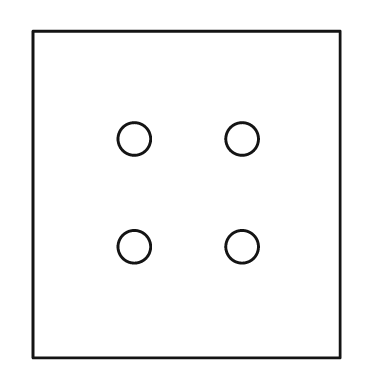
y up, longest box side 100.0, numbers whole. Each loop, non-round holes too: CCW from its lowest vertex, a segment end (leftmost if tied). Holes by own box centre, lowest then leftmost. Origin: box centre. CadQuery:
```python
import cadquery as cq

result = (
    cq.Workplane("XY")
    .moveTo(-47.0, -50.0)
    .lineTo(47.0, -50.0)
    .lineTo(47.0, 50.0)
    .lineTo(-47.0, 50.0)
    .close()
    .moveTo(-16.0, -16.0)
    .circle(5.0)
    .moveTo(17.0, -16.0)
    .circle(5.0)
    .moveTo(-16.0, 17.0)
    .circle(5.0)
    .moveTo(17.0, 17.0)
    .circle(5.0)
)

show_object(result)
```